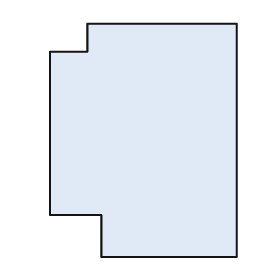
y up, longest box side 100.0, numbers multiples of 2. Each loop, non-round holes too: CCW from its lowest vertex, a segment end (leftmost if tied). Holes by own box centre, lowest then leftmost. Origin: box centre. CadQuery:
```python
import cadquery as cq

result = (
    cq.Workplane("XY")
    .moveTo(-18.0, -50.0)
    .lineTo(40.0, -50.0)
    .lineTo(40.0, 50.0)
    .lineTo(-24.0, 50.0)
    .lineTo(-24.0, 38.0)
    .lineTo(-40.0, 38.0)
    .lineTo(-40.0, -32.0)
    .lineTo(-18.0, -32.0)
    .close()
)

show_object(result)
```